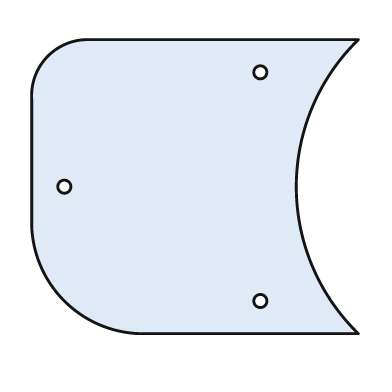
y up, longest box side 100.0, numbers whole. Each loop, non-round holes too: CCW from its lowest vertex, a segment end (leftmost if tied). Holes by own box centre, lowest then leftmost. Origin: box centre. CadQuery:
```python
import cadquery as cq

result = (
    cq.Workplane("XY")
    .moveTo(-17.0, -45.0)
    .lineTo(50.0, -45.0)
    .threePointArc((31.0, 0.0), (50.0, 45.0))
    .lineTo(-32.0, 45.0)
    .threePointArc((-45.0, 40.0), (-50.0, 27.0))
    .lineTo(-50.0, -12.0)
    .threePointArc((-40.0, -35.0), (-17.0, -45.0))
    .close()
    .moveTo(20.0, -35.0)
    .circle(2.0)
    .moveTo(-40.0, 0.0)
    .circle(2.0)
    .moveTo(20.0, 35.0)
    .circle(2.0)
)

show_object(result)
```